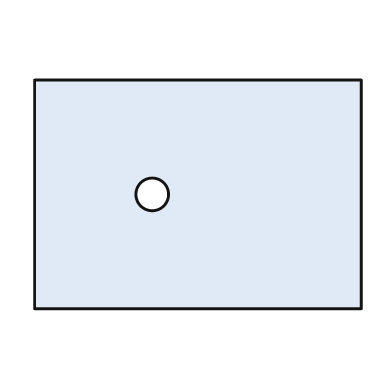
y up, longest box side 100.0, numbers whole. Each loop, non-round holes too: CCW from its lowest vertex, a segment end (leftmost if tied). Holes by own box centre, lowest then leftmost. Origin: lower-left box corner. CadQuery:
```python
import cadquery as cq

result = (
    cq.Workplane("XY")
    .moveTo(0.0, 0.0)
    .lineTo(100.0, 0.0)
    .lineTo(100.0, 70.0)
    .lineTo(0.0, 70.0)
    .close()
    .moveTo(36.0, 35.0)
    .circle(5.0)
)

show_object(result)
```